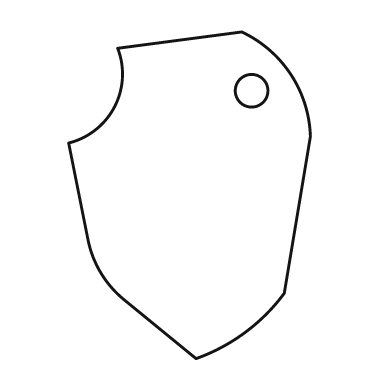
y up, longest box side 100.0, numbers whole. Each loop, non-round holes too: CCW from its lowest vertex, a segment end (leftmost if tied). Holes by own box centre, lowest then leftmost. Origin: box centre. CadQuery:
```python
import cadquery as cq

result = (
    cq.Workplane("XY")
    .moveTo(2.0, -50.0)
    .threePointArc((17.0, -42.0), (29.0, -30.0))
    .lineTo(37.0, 18.0)
    .threePointArc((31.0, 37.0), (16.0, 50.0))
    .lineTo(-22.0, 45.0)
    .threePointArc((-23.0, 27.0), (-37.0, 16.0))
    .lineTo(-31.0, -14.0)
    .threePointArc((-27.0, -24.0), (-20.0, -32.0))
    .close()
    .moveTo(19.0, 32.0)
    .circle(5.0)
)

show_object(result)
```